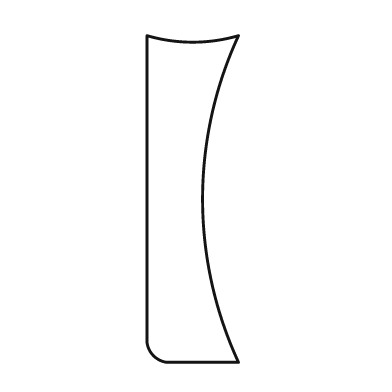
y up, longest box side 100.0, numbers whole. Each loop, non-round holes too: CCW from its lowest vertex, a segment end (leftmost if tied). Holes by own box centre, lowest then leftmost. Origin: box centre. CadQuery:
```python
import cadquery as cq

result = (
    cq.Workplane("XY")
    .moveTo(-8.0, -50.0)
    .lineTo(14.0, -50.0)
    .threePointArc((3.0, 0.0), (14.0, 50.0))
    .threePointArc((0.0, 48.0), (-14.0, 50.0))
    .lineTo(-14.0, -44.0)
    .threePointArc((-12.0, -48.0), (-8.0, -50.0))
    .close()
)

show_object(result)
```